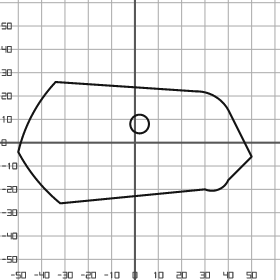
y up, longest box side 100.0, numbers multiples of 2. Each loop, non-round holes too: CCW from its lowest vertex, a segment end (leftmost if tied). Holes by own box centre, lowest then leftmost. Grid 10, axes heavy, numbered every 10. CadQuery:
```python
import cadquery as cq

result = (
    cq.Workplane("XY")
    .moveTo(-32.0, -26.0)
    .lineTo(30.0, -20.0)
    .threePointArc((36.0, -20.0), (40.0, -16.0))
    .lineTo(50.0, -6.0)
    .lineTo(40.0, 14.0)
    .threePointArc((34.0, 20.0), (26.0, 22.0))
    .lineTo(-34.0, 26.0)
    .threePointArc((-44.0, 12.0), (-50.0, -4.0))
    .threePointArc((-42.0, -16.0), (-32.0, -26.0))
    .close()
    .moveTo(2.0, 8.0)
    .circle(4.0)
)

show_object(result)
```